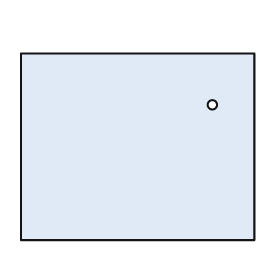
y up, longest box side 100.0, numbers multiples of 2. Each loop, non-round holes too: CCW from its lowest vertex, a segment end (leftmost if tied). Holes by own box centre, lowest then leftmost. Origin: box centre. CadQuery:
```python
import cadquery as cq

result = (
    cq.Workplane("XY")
    .moveTo(-50.0, -40.0)
    .lineTo(50.0, -40.0)
    .lineTo(50.0, 40.0)
    .lineTo(-50.0, 40.0)
    .close()
    .moveTo(32.0, 18.0)
    .circle(2.0)
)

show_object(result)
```